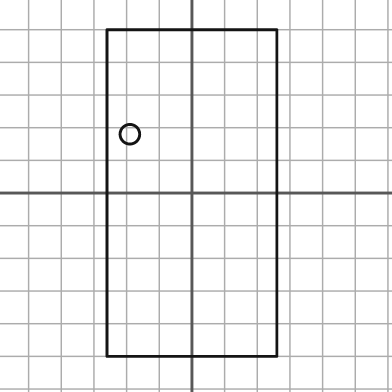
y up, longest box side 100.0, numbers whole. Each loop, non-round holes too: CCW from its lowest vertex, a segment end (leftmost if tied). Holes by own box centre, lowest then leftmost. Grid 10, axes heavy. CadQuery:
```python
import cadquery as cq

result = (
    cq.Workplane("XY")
    .moveTo(-26.0, -50.0)
    .lineTo(26.0, -50.0)
    .lineTo(26.0, 50.0)
    .lineTo(-26.0, 50.0)
    .close()
    .moveTo(-19.0, 18.0)
    .circle(3.0)
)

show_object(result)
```